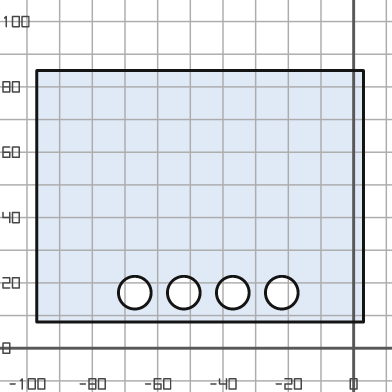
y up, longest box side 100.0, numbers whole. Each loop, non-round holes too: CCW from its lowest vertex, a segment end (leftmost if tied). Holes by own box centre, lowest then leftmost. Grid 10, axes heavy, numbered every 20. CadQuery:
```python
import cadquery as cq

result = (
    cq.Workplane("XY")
    .moveTo(-97.0, 8.0)
    .lineTo(3.0, 8.0)
    .lineTo(3.0, 85.0)
    .lineTo(-97.0, 85.0)
    .close()
    .moveTo(-67.0, 17.0)
    .circle(5.0)
    .moveTo(-52.0, 17.0)
    .circle(5.0)
    .moveTo(-37.0, 17.0)
    .circle(5.0)
    .moveTo(-22.0, 17.0)
    .circle(5.0)
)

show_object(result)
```